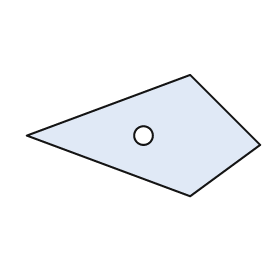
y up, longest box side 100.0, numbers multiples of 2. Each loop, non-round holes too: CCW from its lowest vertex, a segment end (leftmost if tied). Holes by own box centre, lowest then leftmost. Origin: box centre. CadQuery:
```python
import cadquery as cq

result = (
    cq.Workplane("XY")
    .moveTo(20.0, -26.0)
    .lineTo(50.0, -4.0)
    .lineTo(20.0, 26.0)
    .lineTo(-50.0, 0.0)
    .close()
    .moveTo(0.0, 0.0)
    .circle(4.0)
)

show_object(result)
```